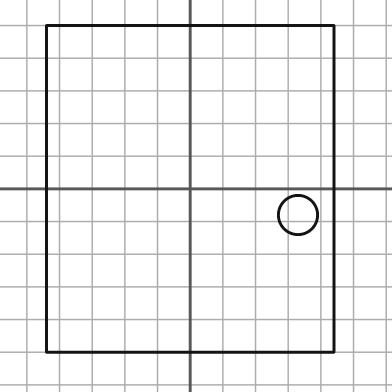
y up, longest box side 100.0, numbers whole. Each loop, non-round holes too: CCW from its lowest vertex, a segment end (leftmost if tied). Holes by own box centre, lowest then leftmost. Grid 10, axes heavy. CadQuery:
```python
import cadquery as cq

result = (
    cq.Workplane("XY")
    .moveTo(-44.0, -50.0)
    .lineTo(44.0, -50.0)
    .lineTo(44.0, 50.0)
    .lineTo(-44.0, 50.0)
    .close()
    .moveTo(33.0, -8.0)
    .circle(6.0)
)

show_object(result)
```